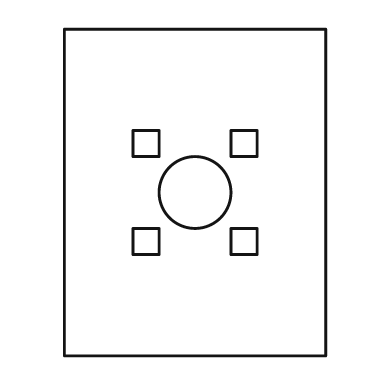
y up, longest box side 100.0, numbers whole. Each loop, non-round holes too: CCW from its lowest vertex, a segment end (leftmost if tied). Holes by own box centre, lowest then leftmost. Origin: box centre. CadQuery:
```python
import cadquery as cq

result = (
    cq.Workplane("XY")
    .moveTo(-40.0, -50.0)
    .lineTo(40.0, -50.0)
    .lineTo(40.0, 50.0)
    .lineTo(-40.0, 50.0)
    .close()
    .moveTo(-19.0, -19.0)
    .lineTo(-11.0, -19.0)
    .lineTo(-11.0, -11.0)
    .lineTo(-19.0, -11.0)
    .close()
    .moveTo(11.0, -19.0)
    .lineTo(19.0, -19.0)
    .lineTo(19.0, -11.0)
    .lineTo(11.0, -11.0)
    .close()
    .moveTo(0.0, 0.0)
    .circle(11.0)
    .moveTo(-19.0, 11.0)
    .lineTo(-11.0, 11.0)
    .lineTo(-11.0, 19.0)
    .lineTo(-19.0, 19.0)
    .close()
    .moveTo(11.0, 11.0)
    .lineTo(19.0, 11.0)
    .lineTo(19.0, 19.0)
    .lineTo(11.0, 19.0)
    .close()
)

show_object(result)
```